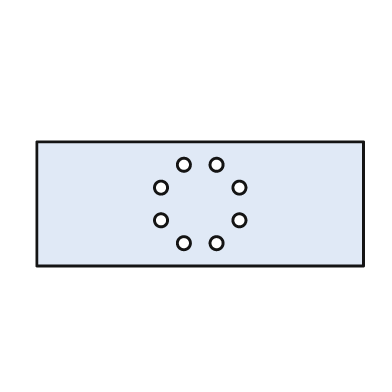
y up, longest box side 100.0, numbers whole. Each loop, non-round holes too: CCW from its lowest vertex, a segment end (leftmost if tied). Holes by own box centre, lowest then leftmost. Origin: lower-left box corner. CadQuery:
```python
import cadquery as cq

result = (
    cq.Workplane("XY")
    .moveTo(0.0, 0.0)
    .lineTo(100.0, 0.0)
    .lineTo(100.0, 38.0)
    .lineTo(0.0, 38.0)
    .close()
    .moveTo(45.0, 7.0)
    .circle(2.0)
    .moveTo(55.0, 7.0)
    .circle(2.0)
    .moveTo(38.0, 14.0)
    .circle(2.0)
    .moveTo(62.0, 14.0)
    .circle(2.0)
    .moveTo(38.0, 24.0)
    .circle(2.0)
    .moveTo(62.0, 24.0)
    .circle(2.0)
    .moveTo(45.0, 31.0)
    .circle(2.0)
    .moveTo(55.0, 31.0)
    .circle(2.0)
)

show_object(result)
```